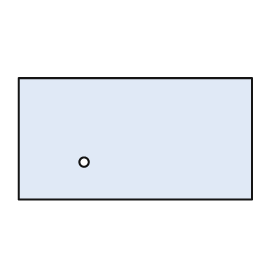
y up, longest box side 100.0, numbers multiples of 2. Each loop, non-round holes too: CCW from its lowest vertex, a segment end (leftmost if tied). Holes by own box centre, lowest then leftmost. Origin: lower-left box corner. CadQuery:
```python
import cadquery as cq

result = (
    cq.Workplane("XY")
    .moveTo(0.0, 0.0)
    .lineTo(100.0, 0.0)
    .lineTo(100.0, 52.0)
    .lineTo(0.0, 52.0)
    .close()
    .moveTo(28.0, 16.0)
    .circle(2.0)
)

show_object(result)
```